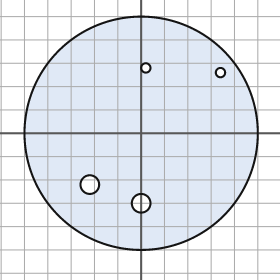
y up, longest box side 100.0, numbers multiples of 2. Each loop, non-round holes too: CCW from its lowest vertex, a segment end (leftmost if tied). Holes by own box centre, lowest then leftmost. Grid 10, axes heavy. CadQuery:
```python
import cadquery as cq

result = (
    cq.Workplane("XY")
    .moveTo(0.0, 0.0)
    .circle(50.0)
    .moveTo(0.0, -30.0)
    .circle(4.0)
    .moveTo(-22.0, -22.0)
    .circle(4.0)
    .moveTo(34.0, 26.0)
    .circle(2.0)
    .moveTo(2.0, 28.0)
    .circle(2.0)
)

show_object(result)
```